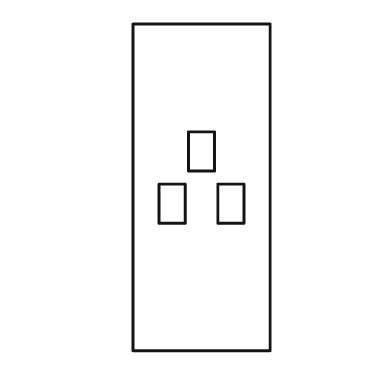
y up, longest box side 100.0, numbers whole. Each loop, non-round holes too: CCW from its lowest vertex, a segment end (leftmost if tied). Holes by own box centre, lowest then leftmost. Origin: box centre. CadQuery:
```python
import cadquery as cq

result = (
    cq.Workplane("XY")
    .moveTo(-21.0, -50.0)
    .lineTo(21.0, -50.0)
    .lineTo(21.0, 50.0)
    .lineTo(-21.0, 50.0)
    .close()
    .moveTo(-13.0, -11.0)
    .lineTo(-5.0, -11.0)
    .lineTo(-5.0, 1.0)
    .lineTo(-13.0, 1.0)
    .close()
    .moveTo(5.0, -11.0)
    .lineTo(13.0, -11.0)
    .lineTo(13.0, 1.0)
    .lineTo(5.0, 1.0)
    .close()
    .moveTo(-4.0, 5.0)
    .lineTo(4.0, 5.0)
    .lineTo(4.0, 17.0)
    .lineTo(-4.0, 17.0)
    .close()
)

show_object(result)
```